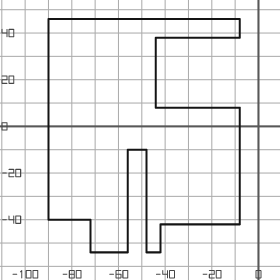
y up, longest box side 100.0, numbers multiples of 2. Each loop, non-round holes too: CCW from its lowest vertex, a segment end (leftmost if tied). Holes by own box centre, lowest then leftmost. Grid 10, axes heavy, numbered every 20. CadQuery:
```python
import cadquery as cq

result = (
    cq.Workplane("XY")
    .moveTo(-72.0, -54.0)
    .lineTo(-56.0, -54.0)
    .lineTo(-56.0, -10.0)
    .lineTo(-48.0, -10.0)
    .lineTo(-48.0, -54.0)
    .lineTo(-42.0, -54.0)
    .lineTo(-42.0, -42.0)
    .lineTo(-8.0, -42.0)
    .lineTo(-8.0, 8.0)
    .lineTo(-44.0, 8.0)
    .lineTo(-44.0, 38.0)
    .lineTo(-8.0, 38.0)
    .lineTo(-8.0, 46.0)
    .lineTo(-90.0, 46.0)
    .lineTo(-90.0, -40.0)
    .lineTo(-72.0, -40.0)
    .close()
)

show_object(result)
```